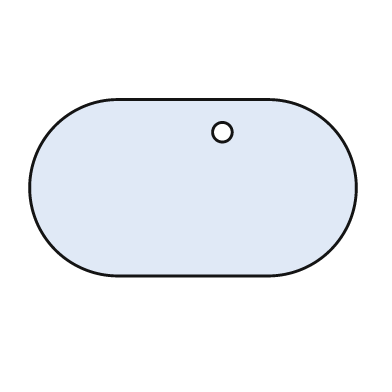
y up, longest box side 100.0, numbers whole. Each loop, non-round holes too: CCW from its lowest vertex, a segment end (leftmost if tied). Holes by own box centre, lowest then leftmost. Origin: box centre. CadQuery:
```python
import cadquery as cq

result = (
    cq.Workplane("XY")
    .moveTo(-23.0, -27.0)
    .lineTo(23.0, -27.0)
    .threePointArc((50.0, 0.0), (23.0, 27.0))
    .lineTo(-23.0, 27.0)
    .threePointArc((-50.0, 0.0), (-23.0, -27.0))
    .close()
    .moveTo(9.0, 17.0)
    .circle(3.0)
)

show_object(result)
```